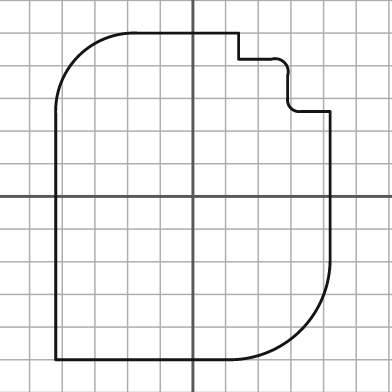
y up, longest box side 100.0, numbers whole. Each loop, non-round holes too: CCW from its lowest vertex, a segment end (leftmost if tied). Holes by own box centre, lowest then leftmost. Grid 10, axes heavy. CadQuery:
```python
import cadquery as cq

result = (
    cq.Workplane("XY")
    .moveTo(-42.0, -50.0)
    .lineTo(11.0, -50.0)
    .threePointArc((33.0, -41.0), (42.0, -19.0))
    .lineTo(42.0, 26.0)
    .lineTo(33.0, 26.0)
    .threePointArc((30.0, 27.0), (29.0, 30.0))
    .lineTo(29.0, 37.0)
    .threePointArc((28.0, 41.0), (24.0, 42.0))
    .lineTo(14.0, 42.0)
    .lineTo(14.0, 50.0)
    .lineTo(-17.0, 50.0)
    .threePointArc((-35.0, 43.0), (-42.0, 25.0))
    .close()
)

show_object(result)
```